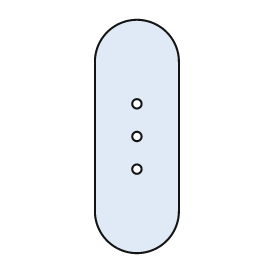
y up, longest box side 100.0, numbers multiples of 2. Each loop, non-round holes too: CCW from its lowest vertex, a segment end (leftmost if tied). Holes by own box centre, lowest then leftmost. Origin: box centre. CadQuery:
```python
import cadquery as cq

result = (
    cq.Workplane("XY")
    .moveTo(-18.0, -32.0)
    .threePointArc((0.0, -50.0), (18.0, -32.0))
    .lineTo(18.0, 32.0)
    .threePointArc((0.0, 50.0), (-18.0, 32.0))
    .close()
    .moveTo(0.0, -14.0)
    .circle(2.0)
    .moveTo(0.0, 0.0)
    .circle(2.0)
    .moveTo(0.0, 14.0)
    .circle(2.0)
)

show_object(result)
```